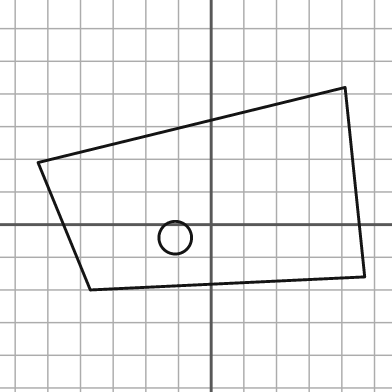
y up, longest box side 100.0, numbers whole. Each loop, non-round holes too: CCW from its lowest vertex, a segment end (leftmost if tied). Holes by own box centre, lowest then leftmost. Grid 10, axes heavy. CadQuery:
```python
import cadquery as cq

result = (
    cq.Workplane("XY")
    .moveTo(-37.0, -20.0)
    .lineTo(47.0, -16.0)
    .lineTo(41.0, 42.0)
    .lineTo(-53.0, 19.0)
    .close()
    .moveTo(-11.0, -4.0)
    .circle(5.0)
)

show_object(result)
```